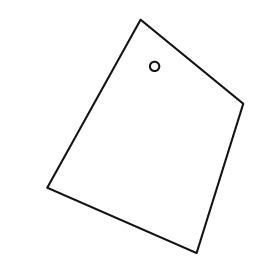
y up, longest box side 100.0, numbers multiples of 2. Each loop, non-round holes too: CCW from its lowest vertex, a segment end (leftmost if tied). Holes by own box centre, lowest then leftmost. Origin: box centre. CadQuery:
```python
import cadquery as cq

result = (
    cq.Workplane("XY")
    .moveTo(22.0, -50.0)
    .lineTo(42.0, 14.0)
    .lineTo(-2.0, 50.0)
    .lineTo(-42.0, -22.0)
    .close()
    .moveTo(4.0, 30.0)
    .circle(2.0)
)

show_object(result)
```